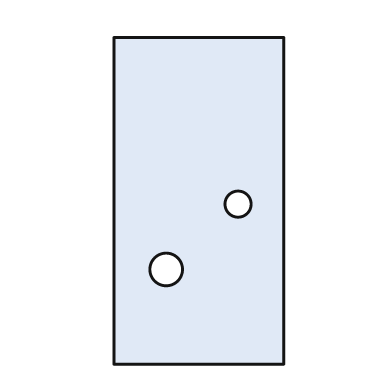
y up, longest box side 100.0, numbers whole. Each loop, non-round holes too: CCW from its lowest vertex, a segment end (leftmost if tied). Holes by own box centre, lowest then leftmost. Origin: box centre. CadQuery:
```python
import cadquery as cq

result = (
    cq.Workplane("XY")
    .moveTo(-26.0, -50.0)
    .lineTo(26.0, -50.0)
    .lineTo(26.0, 50.0)
    .lineTo(-26.0, 50.0)
    .close()
    .moveTo(-10.0, -21.0)
    .circle(5.0)
    .moveTo(12.0, -1.0)
    .circle(4.0)
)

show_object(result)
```